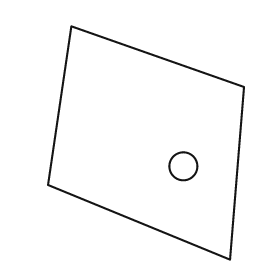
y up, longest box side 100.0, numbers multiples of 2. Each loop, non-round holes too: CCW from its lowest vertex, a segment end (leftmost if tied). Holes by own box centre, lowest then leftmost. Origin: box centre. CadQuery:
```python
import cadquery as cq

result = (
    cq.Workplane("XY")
    .moveTo(36.0, -50.0)
    .lineTo(42.0, 24.0)
    .lineTo(-32.0, 50.0)
    .lineTo(-42.0, -18.0)
    .close()
    .moveTo(16.0, -10.0)
    .circle(6.0)
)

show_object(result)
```